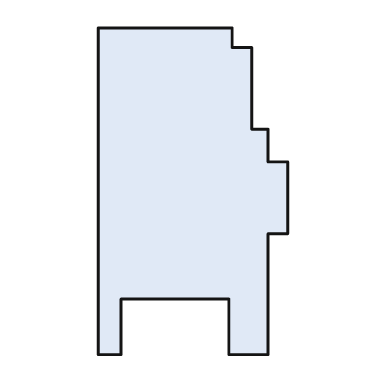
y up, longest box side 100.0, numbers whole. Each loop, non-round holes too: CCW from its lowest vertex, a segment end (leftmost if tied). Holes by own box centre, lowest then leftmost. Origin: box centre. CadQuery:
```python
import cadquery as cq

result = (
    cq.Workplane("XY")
    .moveTo(-29.0, -50.0)
    .lineTo(-22.0, -50.0)
    .lineTo(-22.0, -33.0)
    .lineTo(11.0, -33.0)
    .lineTo(11.0, -50.0)
    .lineTo(23.0, -50.0)
    .lineTo(23.0, -13.0)
    .lineTo(29.0, -13.0)
    .lineTo(29.0, 9.0)
    .lineTo(23.0, 9.0)
    .lineTo(23.0, 19.0)
    .lineTo(18.0, 19.0)
    .lineTo(18.0, 44.0)
    .lineTo(12.0, 44.0)
    .lineTo(12.0, 50.0)
    .lineTo(-29.0, 50.0)
    .close()
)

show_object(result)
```